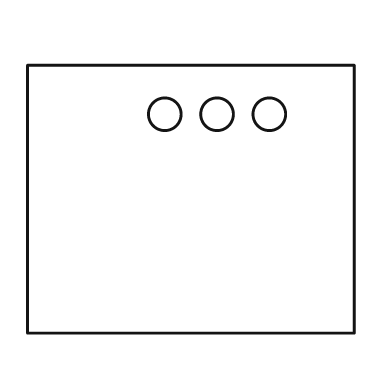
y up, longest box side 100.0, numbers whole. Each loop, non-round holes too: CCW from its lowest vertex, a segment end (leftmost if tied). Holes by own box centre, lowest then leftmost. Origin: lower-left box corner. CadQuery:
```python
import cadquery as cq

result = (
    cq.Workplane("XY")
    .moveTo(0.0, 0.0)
    .lineTo(100.0, 0.0)
    .lineTo(100.0, 82.0)
    .lineTo(0.0, 82.0)
    .close()
    .moveTo(42.0, 67.0)
    .circle(5.0)
    .moveTo(58.0, 67.0)
    .circle(5.0)
    .moveTo(74.0, 67.0)
    .circle(5.0)
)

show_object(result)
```